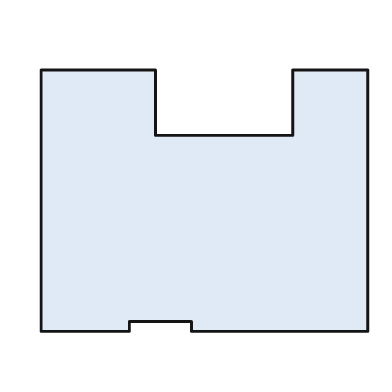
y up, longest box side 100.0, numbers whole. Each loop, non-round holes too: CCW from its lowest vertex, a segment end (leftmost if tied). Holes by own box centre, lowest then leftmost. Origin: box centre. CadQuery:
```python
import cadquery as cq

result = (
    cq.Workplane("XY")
    .moveTo(-50.0, -40.0)
    .lineTo(-23.0, -40.0)
    .lineTo(-23.0, -37.0)
    .lineTo(-4.0, -37.0)
    .lineTo(-4.0, -40.0)
    .lineTo(50.0, -40.0)
    .lineTo(50.0, 40.0)
    .lineTo(27.0, 40.0)
    .lineTo(27.0, 20.0)
    .lineTo(-15.0, 20.0)
    .lineTo(-15.0, 40.0)
    .lineTo(-50.0, 40.0)
    .close()
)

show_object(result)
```